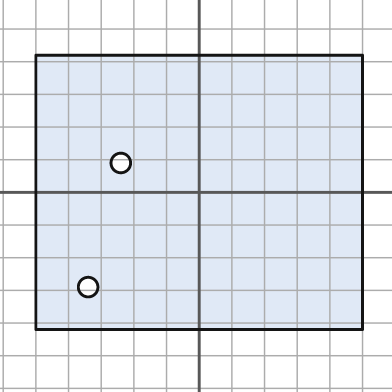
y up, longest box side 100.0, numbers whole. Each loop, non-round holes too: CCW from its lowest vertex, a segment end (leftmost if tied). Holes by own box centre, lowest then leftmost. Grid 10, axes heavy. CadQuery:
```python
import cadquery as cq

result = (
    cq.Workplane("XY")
    .moveTo(-50.0, -42.0)
    .lineTo(50.0, -42.0)
    .lineTo(50.0, 42.0)
    .lineTo(-50.0, 42.0)
    .close()
    .moveTo(-34.0, -29.0)
    .circle(3.0)
    .moveTo(-24.0, 9.0)
    .circle(3.0)
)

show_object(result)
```